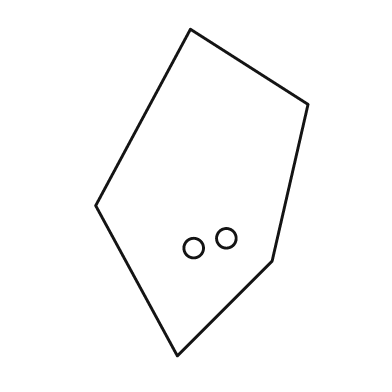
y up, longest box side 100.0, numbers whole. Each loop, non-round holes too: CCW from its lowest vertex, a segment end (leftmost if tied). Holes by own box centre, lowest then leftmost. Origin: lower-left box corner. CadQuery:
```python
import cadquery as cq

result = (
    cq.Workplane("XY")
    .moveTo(25.0, 0.0)
    .lineTo(54.0, 29.0)
    .lineTo(65.0, 77.0)
    .lineTo(29.0, 100.0)
    .lineTo(0.0, 46.0)
    .close()
    .moveTo(30.0, 33.0)
    .circle(3.0)
    .moveTo(40.0, 36.0)
    .circle(3.0)
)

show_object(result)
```